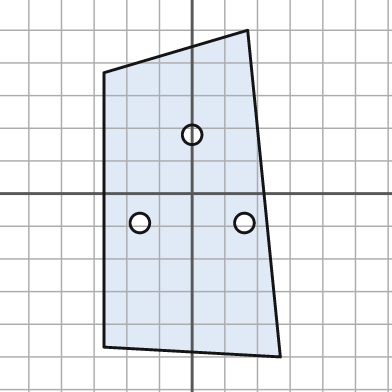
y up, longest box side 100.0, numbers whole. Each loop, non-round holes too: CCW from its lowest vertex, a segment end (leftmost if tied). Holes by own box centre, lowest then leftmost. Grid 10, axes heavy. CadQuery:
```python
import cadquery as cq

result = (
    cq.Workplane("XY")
    .moveTo(27.0, -50.0)
    .lineTo(17.0, 50.0)
    .lineTo(-27.0, 37.0)
    .lineTo(-27.0, -47.0)
    .close()
    .moveTo(-16.0, -9.0)
    .circle(3.0)
    .moveTo(16.0, -9.0)
    .circle(3.0)
    .moveTo(0.0, 18.0)
    .circle(3.0)
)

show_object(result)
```